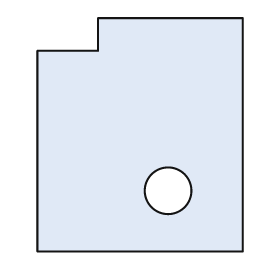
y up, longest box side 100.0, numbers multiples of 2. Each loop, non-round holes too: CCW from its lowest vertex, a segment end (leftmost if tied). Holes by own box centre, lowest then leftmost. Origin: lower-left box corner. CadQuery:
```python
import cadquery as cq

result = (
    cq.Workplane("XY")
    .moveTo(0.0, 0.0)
    .lineTo(88.0, 0.0)
    .lineTo(88.0, 100.0)
    .lineTo(26.0, 100.0)
    .lineTo(26.0, 86.0)
    .lineTo(0.0, 86.0)
    .close()
    .moveTo(56.0, 26.0)
    .circle(10.0)
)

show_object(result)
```